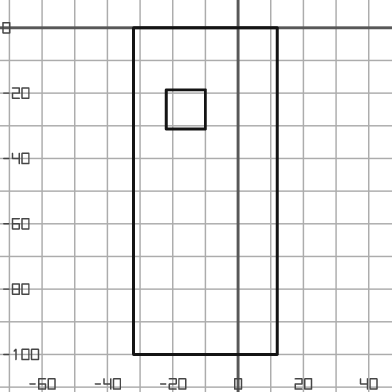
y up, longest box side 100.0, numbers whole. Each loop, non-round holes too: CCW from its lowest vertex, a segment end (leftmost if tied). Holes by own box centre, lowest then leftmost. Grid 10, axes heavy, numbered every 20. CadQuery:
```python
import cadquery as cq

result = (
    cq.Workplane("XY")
    .moveTo(-32.0, -100.0)
    .lineTo(12.0, -100.0)
    .lineTo(12.0, 0.0)
    .lineTo(-32.0, 0.0)
    .close()
    .moveTo(-22.0, -31.0)
    .lineTo(-10.0, -31.0)
    .lineTo(-10.0, -19.0)
    .lineTo(-22.0, -19.0)
    .close()
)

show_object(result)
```